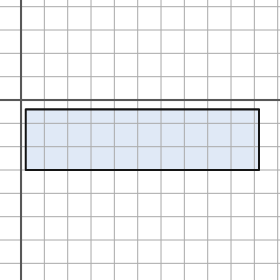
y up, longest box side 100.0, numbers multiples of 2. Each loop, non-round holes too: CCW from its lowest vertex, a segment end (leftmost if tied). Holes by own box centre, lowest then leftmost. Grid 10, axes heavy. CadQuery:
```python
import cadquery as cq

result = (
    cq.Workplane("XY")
    .moveTo(2.0, -30.0)
    .lineTo(102.0, -30.0)
    .lineTo(102.0, -4.0)
    .lineTo(2.0, -4.0)
    .close()
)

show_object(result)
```